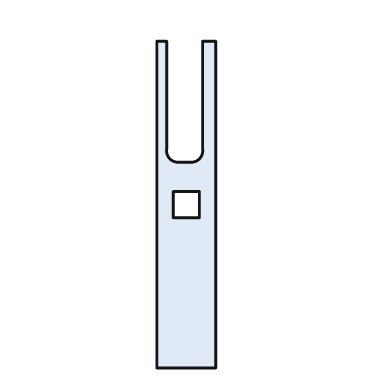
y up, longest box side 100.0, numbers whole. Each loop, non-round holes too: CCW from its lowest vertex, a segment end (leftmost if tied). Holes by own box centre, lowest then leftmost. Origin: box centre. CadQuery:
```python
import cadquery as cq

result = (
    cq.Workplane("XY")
    .moveTo(-9.0, -50.0)
    .lineTo(9.0, -50.0)
    .lineTo(9.0, 50.0)
    .lineTo(5.0, 50.0)
    .lineTo(5.0, 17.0)
    .threePointArc((4.0, 14.0), (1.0, 13.0))
    .lineTo(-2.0, 13.0)
    .threePointArc((-5.0, 14.0), (-6.0, 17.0))
    .lineTo(-6.0, 50.0)
    .lineTo(-9.0, 50.0)
    .close()
    .moveTo(-4.0, -4.0)
    .lineTo(4.0, -4.0)
    .lineTo(4.0, 4.0)
    .lineTo(-4.0, 4.0)
    .close()
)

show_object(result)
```